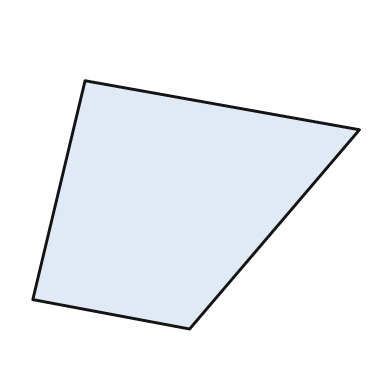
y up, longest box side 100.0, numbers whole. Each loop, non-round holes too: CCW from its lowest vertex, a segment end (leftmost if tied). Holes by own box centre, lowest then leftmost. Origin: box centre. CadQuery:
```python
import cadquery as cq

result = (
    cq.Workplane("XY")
    .moveTo(-2.0, -38.0)
    .lineTo(50.0, 23.0)
    .lineTo(-34.0, 38.0)
    .lineTo(-50.0, -29.0)
    .close()
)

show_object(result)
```